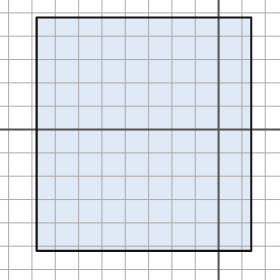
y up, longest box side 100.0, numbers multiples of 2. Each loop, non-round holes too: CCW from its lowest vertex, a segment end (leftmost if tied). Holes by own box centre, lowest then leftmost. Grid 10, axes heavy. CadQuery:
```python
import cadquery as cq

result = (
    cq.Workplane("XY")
    .moveTo(-78.0, -52.0)
    .lineTo(14.0, -52.0)
    .lineTo(14.0, 48.0)
    .lineTo(-78.0, 48.0)
    .close()
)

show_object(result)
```